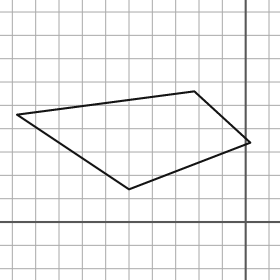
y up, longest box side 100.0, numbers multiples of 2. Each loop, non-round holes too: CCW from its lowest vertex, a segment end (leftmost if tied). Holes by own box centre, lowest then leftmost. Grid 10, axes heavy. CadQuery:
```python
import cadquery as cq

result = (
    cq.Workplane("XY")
    .moveTo(-50.0, 14.0)
    .lineTo(2.0, 34.0)
    .lineTo(-22.0, 56.0)
    .lineTo(-98.0, 46.0)
    .close()
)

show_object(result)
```